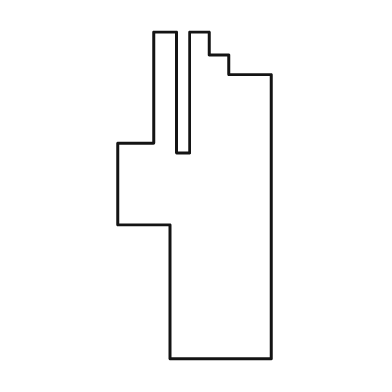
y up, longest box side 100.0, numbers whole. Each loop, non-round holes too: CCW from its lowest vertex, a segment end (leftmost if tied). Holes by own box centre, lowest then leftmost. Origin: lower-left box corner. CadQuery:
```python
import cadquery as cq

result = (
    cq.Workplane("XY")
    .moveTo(16.0, 0.0)
    .lineTo(47.0, 0.0)
    .lineTo(47.0, 87.0)
    .lineTo(34.0, 87.0)
    .lineTo(34.0, 93.0)
    .lineTo(28.0, 93.0)
    .lineTo(28.0, 100.0)
    .lineTo(22.0, 100.0)
    .lineTo(22.0, 63.0)
    .lineTo(18.0, 63.0)
    .lineTo(18.0, 100.0)
    .lineTo(11.0, 100.0)
    .lineTo(11.0, 66.0)
    .lineTo(0.0, 66.0)
    .lineTo(0.0, 41.0)
    .lineTo(16.0, 41.0)
    .close()
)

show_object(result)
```